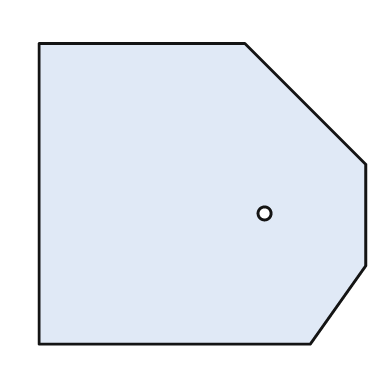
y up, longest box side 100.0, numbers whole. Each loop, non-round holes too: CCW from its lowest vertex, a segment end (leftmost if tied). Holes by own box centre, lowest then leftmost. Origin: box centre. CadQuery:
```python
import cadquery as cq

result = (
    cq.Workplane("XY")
    .moveTo(-50.0, -46.0)
    .lineTo(33.0, -46.0)
    .lineTo(50.0, -22.0)
    .lineTo(50.0, 9.0)
    .lineTo(13.0, 46.0)
    .lineTo(-50.0, 46.0)
    .close()
    .moveTo(19.0, -6.0)
    .circle(2.0)
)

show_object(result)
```